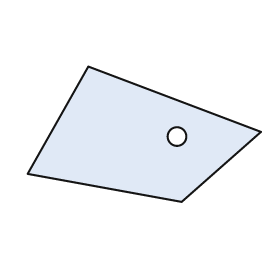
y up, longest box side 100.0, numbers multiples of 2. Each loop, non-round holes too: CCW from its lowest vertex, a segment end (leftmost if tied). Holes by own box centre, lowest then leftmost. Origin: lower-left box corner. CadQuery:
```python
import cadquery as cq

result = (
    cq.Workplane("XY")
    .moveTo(66.0, 0.0)
    .lineTo(100.0, 30.0)
    .lineTo(26.0, 58.0)
    .lineTo(0.0, 12.0)
    .close()
    .moveTo(64.0, 28.0)
    .circle(4.0)
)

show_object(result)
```